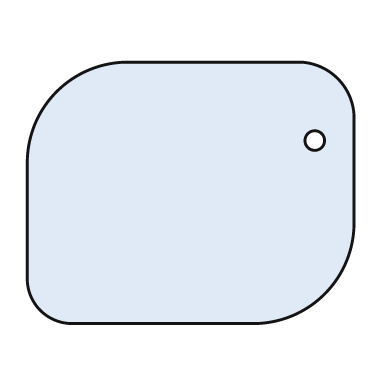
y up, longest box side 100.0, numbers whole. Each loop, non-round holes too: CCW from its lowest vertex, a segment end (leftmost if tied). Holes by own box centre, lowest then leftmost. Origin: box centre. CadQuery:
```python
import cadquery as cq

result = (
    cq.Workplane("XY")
    .moveTo(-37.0, -40.0)
    .lineTo(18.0, -40.0)
    .threePointArc((41.0, -31.0), (50.0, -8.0))
    .lineTo(50.0, 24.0)
    .threePointArc((45.0, 35.0), (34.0, 40.0))
    .lineTo(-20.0, 40.0)
    .threePointArc((-41.0, 31.0), (-50.0, 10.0))
    .lineTo(-50.0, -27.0)
    .threePointArc((-46.0, -36.0), (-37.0, -40.0))
    .close()
    .moveTo(38.0, 16.0)
    .circle(3.0)
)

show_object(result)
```